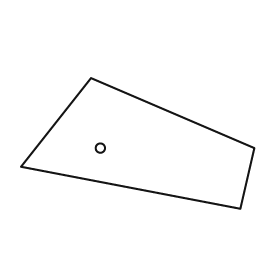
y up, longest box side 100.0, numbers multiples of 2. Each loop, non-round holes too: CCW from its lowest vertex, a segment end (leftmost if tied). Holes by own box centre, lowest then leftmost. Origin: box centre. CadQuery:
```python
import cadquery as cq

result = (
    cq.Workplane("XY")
    .moveTo(44.0, -28.0)
    .lineTo(50.0, -2.0)
    .lineTo(-20.0, 28.0)
    .lineTo(-50.0, -10.0)
    .close()
    .moveTo(-16.0, -2.0)
    .circle(2.0)
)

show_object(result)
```